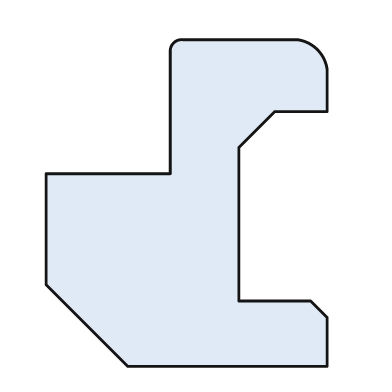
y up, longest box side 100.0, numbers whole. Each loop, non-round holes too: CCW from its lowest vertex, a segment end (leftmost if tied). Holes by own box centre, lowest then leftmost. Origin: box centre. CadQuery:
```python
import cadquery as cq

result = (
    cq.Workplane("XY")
    .moveTo(-18.0, -50.0)
    .lineTo(43.0, -50.0)
    .lineTo(43.0, -35.0)
    .lineTo(38.0, -30.0)
    .lineTo(16.0, -30.0)
    .lineTo(16.0, 17.0)
    .lineTo(27.0, 28.0)
    .lineTo(43.0, 28.0)
    .lineTo(43.0, 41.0)
    .threePointArc((40.0, 47.0), (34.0, 50.0))
    .lineTo(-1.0, 50.0)
    .threePointArc((-4.0, 49.0), (-5.0, 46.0))
    .lineTo(-5.0, 9.0)
    .lineTo(-43.0, 9.0)
    .lineTo(-43.0, -25.0)
    .close()
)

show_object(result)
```